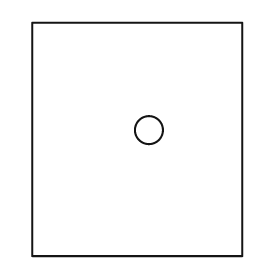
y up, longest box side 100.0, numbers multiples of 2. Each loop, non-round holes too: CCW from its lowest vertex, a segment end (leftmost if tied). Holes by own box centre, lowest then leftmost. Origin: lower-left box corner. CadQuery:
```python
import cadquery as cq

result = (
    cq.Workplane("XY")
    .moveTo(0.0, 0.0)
    .lineTo(90.0, 0.0)
    .lineTo(90.0, 100.0)
    .lineTo(0.0, 100.0)
    .close()
    .moveTo(50.0, 54.0)
    .circle(6.0)
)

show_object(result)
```